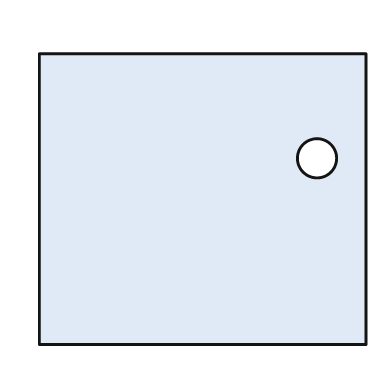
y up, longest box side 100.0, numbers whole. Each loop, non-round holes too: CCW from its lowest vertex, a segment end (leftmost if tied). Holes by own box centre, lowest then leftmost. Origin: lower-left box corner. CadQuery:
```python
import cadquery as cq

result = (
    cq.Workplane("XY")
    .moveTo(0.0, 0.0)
    .lineTo(100.0, 0.0)
    .lineTo(100.0, 89.0)
    .lineTo(0.0, 89.0)
    .close()
    .moveTo(85.0, 57.0)
    .circle(6.0)
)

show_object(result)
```